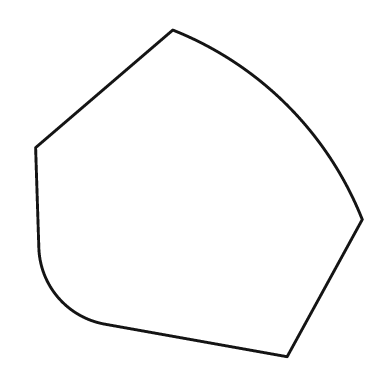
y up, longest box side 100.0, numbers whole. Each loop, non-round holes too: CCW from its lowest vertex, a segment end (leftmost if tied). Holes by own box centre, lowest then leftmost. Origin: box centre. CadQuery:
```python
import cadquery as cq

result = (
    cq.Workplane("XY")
    .moveTo(27.0, -50.0)
    .lineTo(50.0, -8.0)
    .threePointArc((27.0, 27.0), (-8.0, 50.0))
    .lineTo(-50.0, 14.0)
    .lineTo(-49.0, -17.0)
    .threePointArc((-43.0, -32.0), (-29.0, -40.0))
    .close()
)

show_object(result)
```